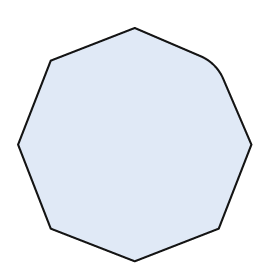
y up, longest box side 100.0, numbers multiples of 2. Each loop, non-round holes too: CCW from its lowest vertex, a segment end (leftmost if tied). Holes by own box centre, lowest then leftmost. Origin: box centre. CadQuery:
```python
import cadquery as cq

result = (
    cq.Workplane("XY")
    .moveTo(0.0, -50.0)
    .lineTo(36.0, -36.0)
    .lineTo(50.0, 0.0)
    .lineTo(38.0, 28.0)
    .threePointArc((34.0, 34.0), (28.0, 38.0))
    .lineTo(0.0, 50.0)
    .lineTo(-36.0, 36.0)
    .lineTo(-50.0, 0.0)
    .lineTo(-36.0, -36.0)
    .close()
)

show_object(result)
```